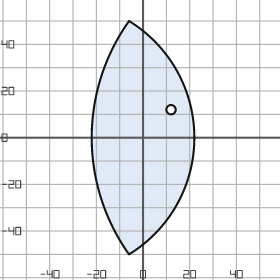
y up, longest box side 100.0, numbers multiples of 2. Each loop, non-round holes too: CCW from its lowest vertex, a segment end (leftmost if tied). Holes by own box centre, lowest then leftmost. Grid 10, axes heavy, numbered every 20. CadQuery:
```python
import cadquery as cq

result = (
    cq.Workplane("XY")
    .moveTo(-6.0, -50.0)
    .threePointArc((22.0, 0.0), (-6.0, 50.0))
    .threePointArc((-22.0, 0.0), (-6.0, -50.0))
    .close()
    .moveTo(12.0, 12.0)
    .circle(2.0)
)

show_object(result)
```